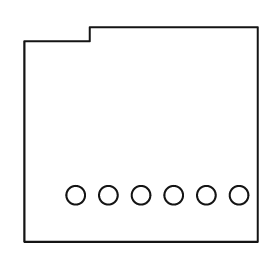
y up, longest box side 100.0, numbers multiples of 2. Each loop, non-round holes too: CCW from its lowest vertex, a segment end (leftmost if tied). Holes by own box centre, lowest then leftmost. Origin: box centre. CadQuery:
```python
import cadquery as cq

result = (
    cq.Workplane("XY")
    .moveTo(-50.0, -46.0)
    .lineTo(50.0, -46.0)
    .lineTo(50.0, 46.0)
    .lineTo(-22.0, 46.0)
    .lineTo(-22.0, 40.0)
    .lineTo(-50.0, 40.0)
    .close()
    .moveTo(-28.0, -26.0)
    .circle(4.0)
    .moveTo(-14.0, -26.0)
    .circle(4.0)
    .moveTo(0.0, -26.0)
    .circle(4.0)
    .moveTo(14.0, -26.0)
    .circle(4.0)
    .moveTo(28.0, -26.0)
    .circle(4.0)
    .moveTo(42.0, -26.0)
    .circle(4.0)
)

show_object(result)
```